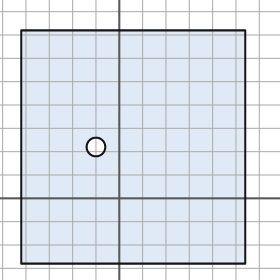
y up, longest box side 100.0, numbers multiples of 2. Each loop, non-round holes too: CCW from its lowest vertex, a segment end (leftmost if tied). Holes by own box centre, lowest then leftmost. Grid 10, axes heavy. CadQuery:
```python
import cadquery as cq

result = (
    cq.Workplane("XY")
    .moveTo(-42.0, -28.0)
    .lineTo(54.0, -28.0)
    .lineTo(54.0, 72.0)
    .lineTo(-42.0, 72.0)
    .close()
    .moveTo(-10.0, 22.0)
    .circle(4.0)
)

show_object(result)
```